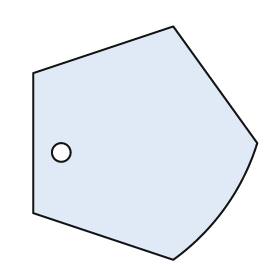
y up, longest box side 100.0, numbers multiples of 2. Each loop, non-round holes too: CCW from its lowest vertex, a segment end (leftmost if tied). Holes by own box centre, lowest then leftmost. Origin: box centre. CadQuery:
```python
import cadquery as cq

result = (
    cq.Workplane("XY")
    .moveTo(12.0, -50.0)
    .threePointArc((34.0, -28.0), (48.0, 0.0))
    .lineTo(12.0, 50.0)
    .lineTo(-48.0, 30.0)
    .lineTo(-48.0, -30.0)
    .close()
    .moveTo(-36.0, -4.0)
    .circle(4.0)
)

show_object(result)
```